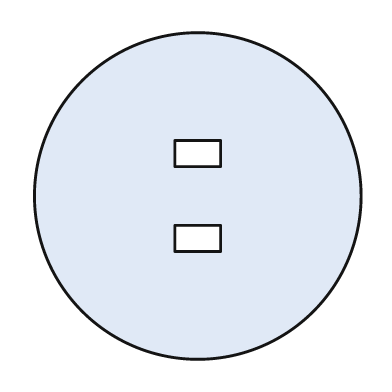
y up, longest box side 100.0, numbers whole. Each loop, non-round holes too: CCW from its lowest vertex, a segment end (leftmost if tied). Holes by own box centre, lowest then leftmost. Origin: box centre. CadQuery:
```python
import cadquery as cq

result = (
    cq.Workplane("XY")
    .moveTo(0.0, 0.0)
    .circle(50.0)
    .moveTo(-7.0, -17.0)
    .lineTo(7.0, -17.0)
    .lineTo(7.0, -9.0)
    .lineTo(-7.0, -9.0)
    .close()
    .moveTo(-7.0, 9.0)
    .lineTo(7.0, 9.0)
    .lineTo(7.0, 17.0)
    .lineTo(-7.0, 17.0)
    .close()
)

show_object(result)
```